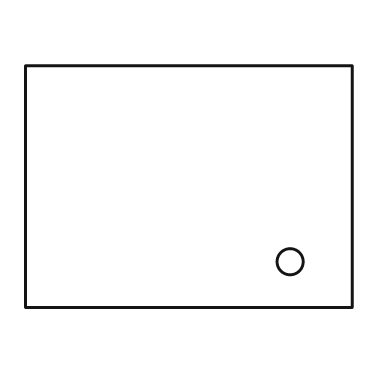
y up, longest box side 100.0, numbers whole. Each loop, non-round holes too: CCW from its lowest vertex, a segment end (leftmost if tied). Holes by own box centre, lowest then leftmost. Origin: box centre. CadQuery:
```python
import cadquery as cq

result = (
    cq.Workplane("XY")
    .moveTo(-50.0, -37.0)
    .lineTo(50.0, -37.0)
    .lineTo(50.0, 37.0)
    .lineTo(-50.0, 37.0)
    .close()
    .moveTo(31.0, -23.0)
    .circle(4.0)
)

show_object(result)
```